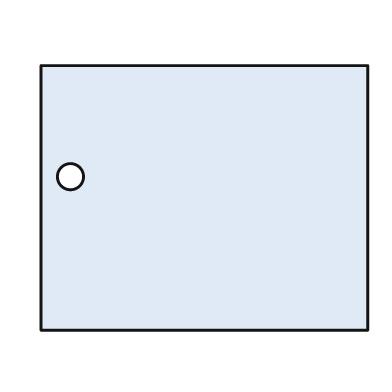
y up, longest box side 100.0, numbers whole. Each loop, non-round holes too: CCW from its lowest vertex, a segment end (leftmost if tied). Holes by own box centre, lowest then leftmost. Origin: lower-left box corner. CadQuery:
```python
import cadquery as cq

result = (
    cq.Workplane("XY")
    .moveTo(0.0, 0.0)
    .lineTo(100.0, 0.0)
    .lineTo(100.0, 81.0)
    .lineTo(0.0, 81.0)
    .close()
    .moveTo(9.0, 47.0)
    .circle(4.0)
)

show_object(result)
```